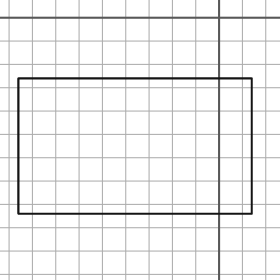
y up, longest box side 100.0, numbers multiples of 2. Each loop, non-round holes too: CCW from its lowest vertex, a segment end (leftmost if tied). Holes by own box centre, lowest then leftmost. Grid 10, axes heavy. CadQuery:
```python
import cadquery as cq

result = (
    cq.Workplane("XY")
    .moveTo(-86.0, -84.0)
    .lineTo(14.0, -84.0)
    .lineTo(14.0, -26.0)
    .lineTo(-86.0, -26.0)
    .close()
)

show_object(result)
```